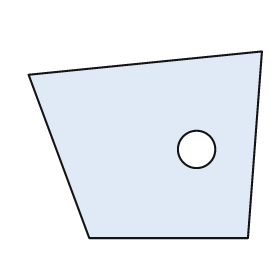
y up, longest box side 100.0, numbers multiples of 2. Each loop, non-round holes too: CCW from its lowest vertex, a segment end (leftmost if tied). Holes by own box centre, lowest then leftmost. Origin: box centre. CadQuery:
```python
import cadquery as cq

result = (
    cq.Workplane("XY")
    .moveTo(-24.0, -40.0)
    .lineTo(44.0, -40.0)
    .lineTo(50.0, 40.0)
    .lineTo(-50.0, 30.0)
    .close()
    .moveTo(22.0, -2.0)
    .circle(8.0)
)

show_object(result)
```